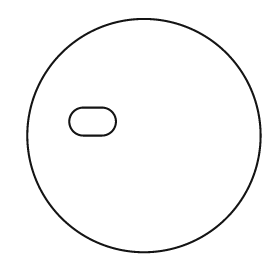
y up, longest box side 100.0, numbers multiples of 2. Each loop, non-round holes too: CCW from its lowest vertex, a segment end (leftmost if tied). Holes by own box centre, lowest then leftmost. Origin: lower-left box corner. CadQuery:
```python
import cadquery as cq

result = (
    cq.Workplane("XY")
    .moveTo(50.0, 50.0)
    .circle(50.0)
    .moveTo(24.0, 50.0)
    .lineTo(32.0, 50.0)
    .threePointArc((38.0, 56.0), (32.0, 62.0))
    .lineTo(24.0, 62.0)
    .threePointArc((18.0, 56.0), (24.0, 50.0))
    .close()
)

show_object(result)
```